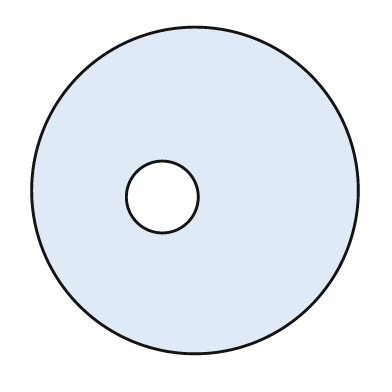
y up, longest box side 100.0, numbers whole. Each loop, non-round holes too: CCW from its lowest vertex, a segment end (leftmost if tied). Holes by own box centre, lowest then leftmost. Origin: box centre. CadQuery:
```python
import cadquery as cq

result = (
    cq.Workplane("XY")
    .moveTo(0.0, 0.0)
    .circle(50.0)
    .moveTo(-10.0, -2.0)
    .circle(11.0)
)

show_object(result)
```